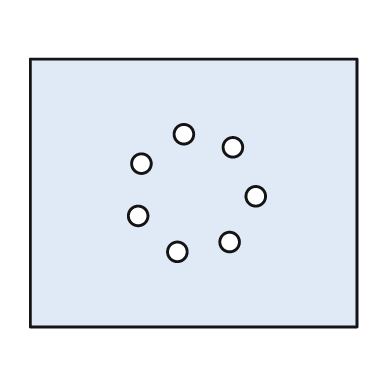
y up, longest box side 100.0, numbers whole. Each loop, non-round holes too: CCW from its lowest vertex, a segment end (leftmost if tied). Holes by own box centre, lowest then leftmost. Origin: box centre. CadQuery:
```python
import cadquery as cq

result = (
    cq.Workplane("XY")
    .moveTo(-50.0, -41.0)
    .lineTo(50.0, -41.0)
    .lineTo(50.0, 41.0)
    .lineTo(-50.0, 41.0)
    .close()
    .moveTo(-5.0, -18.0)
    .circle(3.0)
    .moveTo(11.0, -15.0)
    .circle(3.0)
    .moveTo(-17.0, -7.0)
    .circle(3.0)
    .moveTo(19.0, -1.0)
    .circle(3.0)
    .moveTo(-16.0, 9.0)
    .circle(3.0)
    .moveTo(12.0, 14.0)
    .circle(3.0)
    .moveTo(-3.0, 18.0)
    .circle(3.0)
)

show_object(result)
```